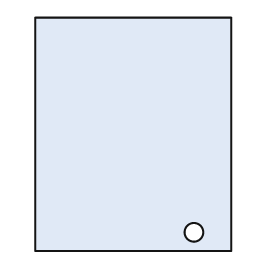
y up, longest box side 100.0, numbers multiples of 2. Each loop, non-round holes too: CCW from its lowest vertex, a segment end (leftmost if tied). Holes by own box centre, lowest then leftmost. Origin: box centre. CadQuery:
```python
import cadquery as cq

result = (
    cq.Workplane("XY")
    .moveTo(-42.0, -50.0)
    .lineTo(42.0, -50.0)
    .lineTo(42.0, 50.0)
    .lineTo(-42.0, 50.0)
    .close()
    .moveTo(26.0, -42.0)
    .circle(4.0)
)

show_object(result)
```